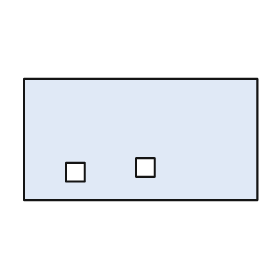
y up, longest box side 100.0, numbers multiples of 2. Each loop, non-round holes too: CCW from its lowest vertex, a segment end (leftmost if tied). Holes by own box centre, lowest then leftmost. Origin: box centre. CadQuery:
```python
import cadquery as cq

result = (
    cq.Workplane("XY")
    .moveTo(-50.0, -26.0)
    .lineTo(50.0, -26.0)
    .lineTo(50.0, 26.0)
    .lineTo(-50.0, 26.0)
    .close()
    .moveTo(-32.0, -18.0)
    .lineTo(-24.0, -18.0)
    .lineTo(-24.0, -10.0)
    .lineTo(-32.0, -10.0)
    .close()
    .moveTo(-2.0, -16.0)
    .lineTo(6.0, -16.0)
    .lineTo(6.0, -8.0)
    .lineTo(-2.0, -8.0)
    .close()
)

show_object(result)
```